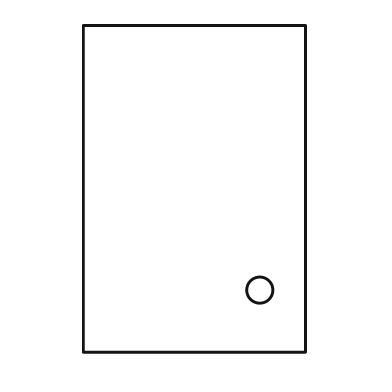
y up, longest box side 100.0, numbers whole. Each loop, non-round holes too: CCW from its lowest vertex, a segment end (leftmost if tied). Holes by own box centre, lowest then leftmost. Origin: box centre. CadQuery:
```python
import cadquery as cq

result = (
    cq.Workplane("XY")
    .moveTo(-34.0, -50.0)
    .lineTo(34.0, -50.0)
    .lineTo(34.0, 50.0)
    .lineTo(-34.0, 50.0)
    .close()
    .moveTo(20.0, -31.0)
    .circle(4.0)
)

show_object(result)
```